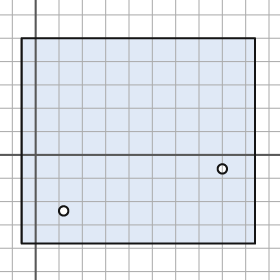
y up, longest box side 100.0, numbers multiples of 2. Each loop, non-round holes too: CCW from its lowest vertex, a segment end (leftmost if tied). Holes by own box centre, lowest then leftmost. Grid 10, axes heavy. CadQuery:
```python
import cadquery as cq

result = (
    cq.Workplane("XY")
    .moveTo(-6.0, -38.0)
    .lineTo(94.0, -38.0)
    .lineTo(94.0, 50.0)
    .lineTo(-6.0, 50.0)
    .close()
    .moveTo(12.0, -24.0)
    .circle(2.0)
    .moveTo(80.0, -6.0)
    .circle(2.0)
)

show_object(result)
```